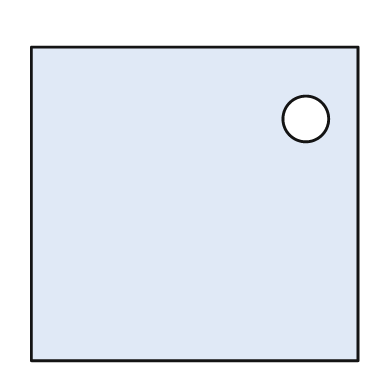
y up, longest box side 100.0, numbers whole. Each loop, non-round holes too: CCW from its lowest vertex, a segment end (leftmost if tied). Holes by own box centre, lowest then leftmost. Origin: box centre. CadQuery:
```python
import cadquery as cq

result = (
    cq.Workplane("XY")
    .moveTo(-50.0, -48.0)
    .lineTo(50.0, -48.0)
    .lineTo(50.0, 48.0)
    .lineTo(-50.0, 48.0)
    .close()
    .moveTo(34.0, 26.0)
    .circle(7.0)
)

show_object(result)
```